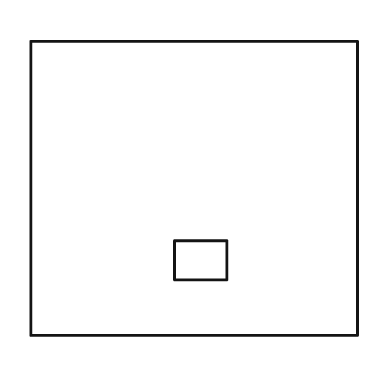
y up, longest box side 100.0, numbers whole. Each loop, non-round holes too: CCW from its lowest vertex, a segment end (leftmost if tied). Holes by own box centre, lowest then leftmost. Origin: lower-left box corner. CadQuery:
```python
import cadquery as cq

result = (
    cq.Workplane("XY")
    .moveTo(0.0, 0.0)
    .lineTo(100.0, 0.0)
    .lineTo(100.0, 90.0)
    .lineTo(0.0, 90.0)
    .close()
    .moveTo(44.0, 17.0)
    .lineTo(60.0, 17.0)
    .lineTo(60.0, 29.0)
    .lineTo(44.0, 29.0)
    .close()
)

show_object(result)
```